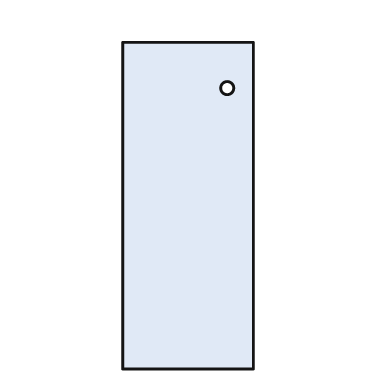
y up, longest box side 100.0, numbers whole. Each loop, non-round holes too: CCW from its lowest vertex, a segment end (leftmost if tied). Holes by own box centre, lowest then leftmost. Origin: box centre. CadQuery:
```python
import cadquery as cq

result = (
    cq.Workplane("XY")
    .moveTo(-20.0, -50.0)
    .lineTo(20.0, -50.0)
    .lineTo(20.0, 50.0)
    .lineTo(-20.0, 50.0)
    .close()
    .moveTo(12.0, 36.0)
    .circle(2.0)
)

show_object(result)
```